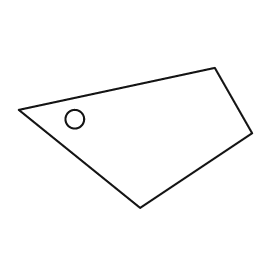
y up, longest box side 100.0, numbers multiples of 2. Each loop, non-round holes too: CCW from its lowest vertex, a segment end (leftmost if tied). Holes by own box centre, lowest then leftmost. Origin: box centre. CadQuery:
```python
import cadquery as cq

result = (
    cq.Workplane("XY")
    .moveTo(2.0, -30.0)
    .lineTo(50.0, 2.0)
    .lineTo(34.0, 30.0)
    .lineTo(-50.0, 12.0)
    .close()
    .moveTo(-26.0, 8.0)
    .circle(4.0)
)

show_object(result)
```